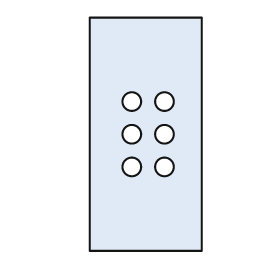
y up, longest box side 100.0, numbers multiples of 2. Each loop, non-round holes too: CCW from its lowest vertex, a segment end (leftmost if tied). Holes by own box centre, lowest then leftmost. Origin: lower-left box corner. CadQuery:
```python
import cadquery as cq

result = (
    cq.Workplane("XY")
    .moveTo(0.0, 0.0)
    .lineTo(48.0, 0.0)
    .lineTo(48.0, 100.0)
    .lineTo(0.0, 100.0)
    .close()
    .moveTo(18.0, 36.0)
    .circle(4.0)
    .moveTo(32.0, 36.0)
    .circle(4.0)
    .moveTo(18.0, 50.0)
    .circle(4.0)
    .moveTo(32.0, 50.0)
    .circle(4.0)
    .moveTo(18.0, 64.0)
    .circle(4.0)
    .moveTo(32.0, 64.0)
    .circle(4.0)
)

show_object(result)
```